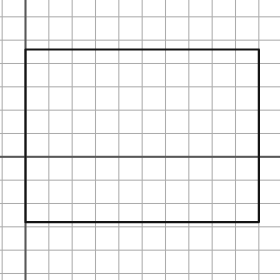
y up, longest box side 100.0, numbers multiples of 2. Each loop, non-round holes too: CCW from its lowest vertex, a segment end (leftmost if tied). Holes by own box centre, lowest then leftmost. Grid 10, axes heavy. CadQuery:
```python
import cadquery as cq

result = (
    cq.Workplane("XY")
    .moveTo(0.0, -28.0)
    .lineTo(100.0, -28.0)
    .lineTo(100.0, 46.0)
    .lineTo(0.0, 46.0)
    .close()
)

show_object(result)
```